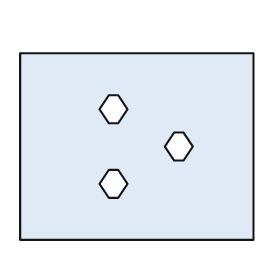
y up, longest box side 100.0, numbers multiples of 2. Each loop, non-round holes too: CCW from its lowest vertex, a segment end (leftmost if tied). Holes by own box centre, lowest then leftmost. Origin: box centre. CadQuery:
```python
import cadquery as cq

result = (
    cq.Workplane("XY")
    .moveTo(-50.0, -40.0)
    .lineTo(50.0, -40.0)
    .lineTo(50.0, 40.0)
    .lineTo(-50.0, 40.0)
    .close()
    .moveTo(-12.0, -22.0)
    .lineTo(-8.0, -22.0)
    .lineTo(-4.0, -16.0)
    .lineTo(-8.0, -10.0)
    .lineTo(-12.0, -10.0)
    .lineTo(-16.0, -16.0)
    .close()
    .moveTo(16.0, -6.0)
    .lineTo(20.0, -6.0)
    .lineTo(24.0, 0.0)
    .lineTo(20.0, 6.0)
    .lineTo(16.0, 6.0)
    .lineTo(12.0, 0.0)
    .close()
    .moveTo(-12.0, 10.0)
    .lineTo(-8.0, 10.0)
    .lineTo(-4.0, 16.0)
    .lineTo(-8.0, 22.0)
    .lineTo(-12.0, 22.0)
    .lineTo(-16.0, 16.0)
    .close()
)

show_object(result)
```